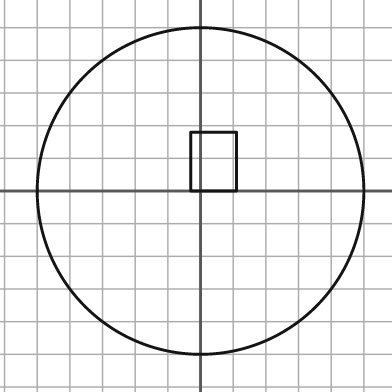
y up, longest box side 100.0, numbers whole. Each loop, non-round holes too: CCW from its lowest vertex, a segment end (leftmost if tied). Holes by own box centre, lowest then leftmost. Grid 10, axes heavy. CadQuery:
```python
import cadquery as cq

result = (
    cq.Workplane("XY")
    .moveTo(0.0, 0.0)
    .circle(50.0)
    .moveTo(-3.0, 0.0)
    .lineTo(11.0, 0.0)
    .lineTo(11.0, 18.0)
    .lineTo(-3.0, 18.0)
    .close()
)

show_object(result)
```